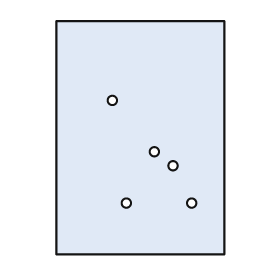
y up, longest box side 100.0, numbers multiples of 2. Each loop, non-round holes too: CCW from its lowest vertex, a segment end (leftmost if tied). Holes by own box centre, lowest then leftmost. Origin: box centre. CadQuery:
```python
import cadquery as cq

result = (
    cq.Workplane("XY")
    .moveTo(-36.0, -50.0)
    .lineTo(36.0, -50.0)
    .lineTo(36.0, 50.0)
    .lineTo(-36.0, 50.0)
    .close()
    .moveTo(-6.0, -28.0)
    .circle(2.0)
    .moveTo(22.0, -28.0)
    .circle(2.0)
    .moveTo(14.0, -12.0)
    .circle(2.0)
    .moveTo(6.0, -6.0)
    .circle(2.0)
    .moveTo(-12.0, 16.0)
    .circle(2.0)
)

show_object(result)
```